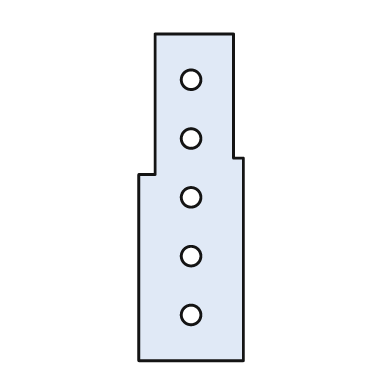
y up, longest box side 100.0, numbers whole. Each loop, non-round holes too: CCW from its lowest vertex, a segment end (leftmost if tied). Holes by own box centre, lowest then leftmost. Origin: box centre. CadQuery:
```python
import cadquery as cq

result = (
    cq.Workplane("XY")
    .moveTo(-16.0, -50.0)
    .lineTo(16.0, -50.0)
    .lineTo(16.0, 12.0)
    .lineTo(13.0, 12.0)
    .lineTo(13.0, 50.0)
    .lineTo(-11.0, 50.0)
    .lineTo(-11.0, 7.0)
    .lineTo(-16.0, 7.0)
    .close()
    .moveTo(0.0, -36.0)
    .circle(3.0)
    .moveTo(0.0, -18.0)
    .circle(3.0)
    .moveTo(0.0, 0.0)
    .circle(3.0)
    .moveTo(0.0, 18.0)
    .circle(3.0)
    .moveTo(0.0, 36.0)
    .circle(3.0)
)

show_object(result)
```